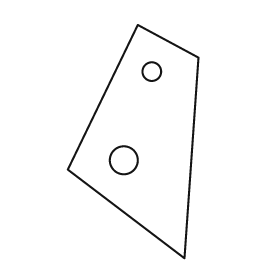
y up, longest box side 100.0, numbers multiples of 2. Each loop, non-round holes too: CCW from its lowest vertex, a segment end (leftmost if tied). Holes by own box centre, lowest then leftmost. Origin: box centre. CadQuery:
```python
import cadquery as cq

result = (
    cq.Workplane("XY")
    .moveTo(22.0, -50.0)
    .lineTo(28.0, 36.0)
    .lineTo(2.0, 50.0)
    .lineTo(-28.0, -12.0)
    .close()
    .moveTo(-4.0, -8.0)
    .circle(6.0)
    .moveTo(8.0, 30.0)
    .circle(4.0)
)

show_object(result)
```